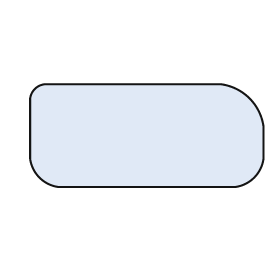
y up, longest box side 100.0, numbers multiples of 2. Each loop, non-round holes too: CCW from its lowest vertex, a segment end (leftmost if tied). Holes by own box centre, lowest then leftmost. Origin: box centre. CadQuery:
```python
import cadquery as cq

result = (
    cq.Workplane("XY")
    .moveTo(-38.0, -22.0)
    .lineTo(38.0, -22.0)
    .threePointArc((46.0, -18.0), (50.0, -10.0))
    .lineTo(50.0, 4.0)
    .threePointArc((44.0, 16.0), (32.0, 22.0))
    .lineTo(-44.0, 22.0)
    .threePointArc((-48.0, 20.0), (-50.0, 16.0))
    .lineTo(-50.0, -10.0)
    .threePointArc((-46.0, -18.0), (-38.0, -22.0))
    .close()
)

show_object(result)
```